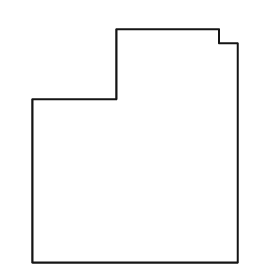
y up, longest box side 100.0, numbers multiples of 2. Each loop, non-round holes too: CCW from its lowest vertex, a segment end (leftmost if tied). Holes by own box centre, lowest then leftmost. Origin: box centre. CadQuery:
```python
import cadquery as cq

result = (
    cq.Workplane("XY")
    .moveTo(-44.0, -50.0)
    .lineTo(44.0, -50.0)
    .lineTo(44.0, 44.0)
    .lineTo(36.0, 44.0)
    .lineTo(36.0, 50.0)
    .lineTo(-8.0, 50.0)
    .lineTo(-8.0, 20.0)
    .lineTo(-44.0, 20.0)
    .close()
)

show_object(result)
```